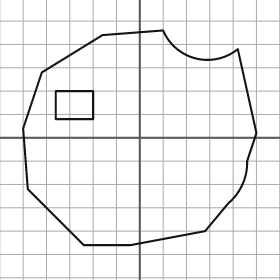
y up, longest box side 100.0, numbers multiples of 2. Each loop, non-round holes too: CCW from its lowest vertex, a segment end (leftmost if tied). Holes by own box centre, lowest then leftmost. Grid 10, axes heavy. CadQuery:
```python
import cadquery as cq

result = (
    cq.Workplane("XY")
    .moveTo(-24.0, -46.0)
    .lineTo(-4.0, -46.0)
    .lineTo(28.0, -40.0)
    .lineTo(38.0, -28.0)
    .threePointArc((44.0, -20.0), (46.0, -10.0))
    .lineTo(50.0, 2.0)
    .lineTo(42.0, 38.0)
    .threePointArc((24.0, 34.0), (10.0, 46.0))
    .lineTo(-16.0, 44.0)
    .lineTo(-42.0, 28.0)
    .lineTo(-50.0, 4.0)
    .lineTo(-48.0, -22.0)
    .close()
    .moveTo(-36.0, 8.0)
    .lineTo(-20.0, 8.0)
    .lineTo(-20.0, 20.0)
    .lineTo(-36.0, 20.0)
    .close()
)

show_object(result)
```